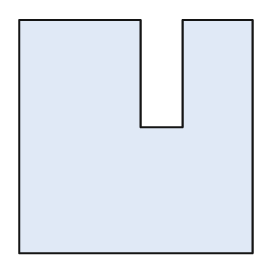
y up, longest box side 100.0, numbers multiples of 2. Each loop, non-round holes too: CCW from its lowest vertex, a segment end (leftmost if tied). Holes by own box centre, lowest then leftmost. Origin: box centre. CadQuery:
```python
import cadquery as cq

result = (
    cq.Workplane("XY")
    .moveTo(-50.0, -50.0)
    .lineTo(50.0, -50.0)
    .lineTo(50.0, 50.0)
    .lineTo(20.0, 50.0)
    .lineTo(20.0, 4.0)
    .lineTo(2.0, 4.0)
    .lineTo(2.0, 50.0)
    .lineTo(-50.0, 50.0)
    .close()
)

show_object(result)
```